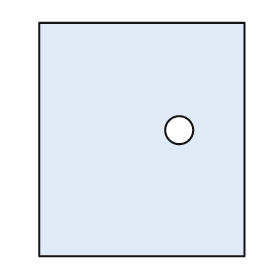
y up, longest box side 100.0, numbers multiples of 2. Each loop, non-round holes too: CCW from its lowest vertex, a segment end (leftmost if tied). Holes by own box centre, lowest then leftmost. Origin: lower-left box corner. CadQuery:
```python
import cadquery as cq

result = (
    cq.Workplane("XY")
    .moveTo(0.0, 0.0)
    .lineTo(88.0, 0.0)
    .lineTo(88.0, 100.0)
    .lineTo(0.0, 100.0)
    .close()
    .moveTo(60.0, 54.0)
    .circle(6.0)
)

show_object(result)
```